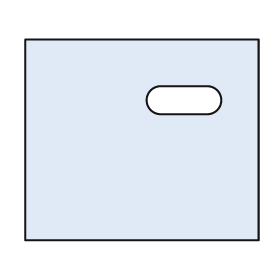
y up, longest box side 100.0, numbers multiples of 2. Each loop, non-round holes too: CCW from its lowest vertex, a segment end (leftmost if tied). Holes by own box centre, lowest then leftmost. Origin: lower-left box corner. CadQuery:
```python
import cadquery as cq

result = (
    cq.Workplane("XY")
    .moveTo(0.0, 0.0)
    .lineTo(100.0, 0.0)
    .lineTo(100.0, 86.0)
    .lineTo(0.0, 86.0)
    .close()
    .moveTo(58.0, 54.0)
    .lineTo(78.0, 54.0)
    .threePointArc((84.0, 60.0), (78.0, 66.0))
    .lineTo(58.0, 66.0)
    .threePointArc((52.0, 60.0), (58.0, 54.0))
    .close()
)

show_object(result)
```